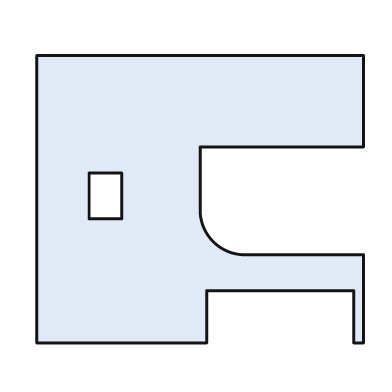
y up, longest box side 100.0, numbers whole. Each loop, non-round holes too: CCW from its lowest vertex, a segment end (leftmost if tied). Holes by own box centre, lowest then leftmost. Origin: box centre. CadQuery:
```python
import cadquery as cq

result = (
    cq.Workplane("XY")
    .moveTo(-50.0, -44.0)
    .lineTo(2.0, -44.0)
    .lineTo(2.0, -28.0)
    .lineTo(47.0, -28.0)
    .lineTo(47.0, -44.0)
    .lineTo(50.0, -44.0)
    .lineTo(50.0, -17.0)
    .lineTo(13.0, -17.0)
    .threePointArc((4.0, -13.0), (0.0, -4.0))
    .lineTo(0.0, 16.0)
    .lineTo(50.0, 16.0)
    .lineTo(50.0, 44.0)
    .lineTo(-50.0, 44.0)
    .close()
    .moveTo(-34.0, -6.0)
    .lineTo(-24.0, -6.0)
    .lineTo(-24.0, 8.0)
    .lineTo(-34.0, 8.0)
    .close()
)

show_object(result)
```